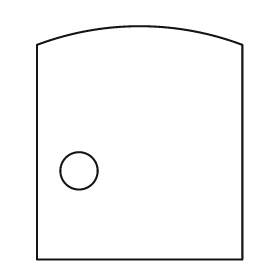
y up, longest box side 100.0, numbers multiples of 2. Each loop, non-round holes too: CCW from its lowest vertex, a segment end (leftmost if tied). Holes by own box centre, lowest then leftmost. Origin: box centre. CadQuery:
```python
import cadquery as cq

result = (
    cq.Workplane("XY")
    .moveTo(-44.0, -50.0)
    .lineTo(44.0, -50.0)
    .lineTo(44.0, 42.0)
    .threePointArc((0.0, 50.0), (-44.0, 42.0))
    .close()
    .moveTo(-26.0, -12.0)
    .circle(8.0)
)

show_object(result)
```